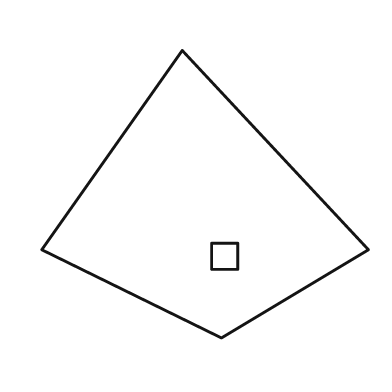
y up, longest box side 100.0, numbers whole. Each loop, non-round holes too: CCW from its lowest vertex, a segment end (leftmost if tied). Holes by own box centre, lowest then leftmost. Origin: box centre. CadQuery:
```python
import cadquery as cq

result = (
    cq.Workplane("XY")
    .moveTo(5.0, -44.0)
    .lineTo(50.0, -17.0)
    .lineTo(-7.0, 44.0)
    .lineTo(-50.0, -17.0)
    .close()
    .moveTo(2.0, -23.0)
    .lineTo(10.0, -23.0)
    .lineTo(10.0, -15.0)
    .lineTo(2.0, -15.0)
    .close()
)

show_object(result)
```